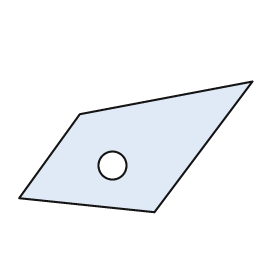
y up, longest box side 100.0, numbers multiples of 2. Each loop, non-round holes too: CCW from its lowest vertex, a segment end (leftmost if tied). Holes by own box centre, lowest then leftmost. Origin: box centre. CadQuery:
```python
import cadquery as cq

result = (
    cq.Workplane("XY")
    .moveTo(8.0, -28.0)
    .lineTo(50.0, 28.0)
    .lineTo(-24.0, 14.0)
    .lineTo(-50.0, -22.0)
    .close()
    .moveTo(-10.0, -8.0)
    .circle(6.0)
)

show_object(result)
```